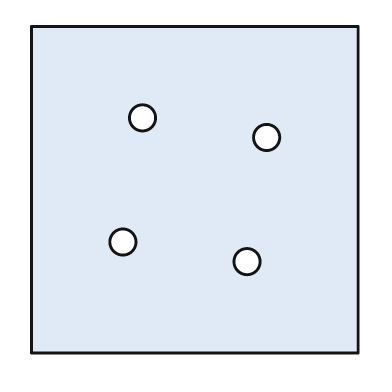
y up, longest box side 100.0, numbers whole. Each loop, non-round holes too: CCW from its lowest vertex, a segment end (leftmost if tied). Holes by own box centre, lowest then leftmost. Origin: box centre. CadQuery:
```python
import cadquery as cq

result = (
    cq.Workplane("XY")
    .moveTo(-50.0, -50.0)
    .lineTo(50.0, -50.0)
    .lineTo(50.0, 50.0)
    .lineTo(-50.0, 50.0)
    .close()
    .moveTo(16.0, -22.0)
    .circle(4.0)
    .moveTo(-22.0, -16.0)
    .circle(4.0)
    .moveTo(22.0, 16.0)
    .circle(4.0)
    .moveTo(-16.0, 22.0)
    .circle(4.0)
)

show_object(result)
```